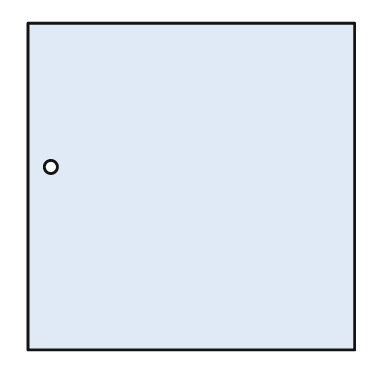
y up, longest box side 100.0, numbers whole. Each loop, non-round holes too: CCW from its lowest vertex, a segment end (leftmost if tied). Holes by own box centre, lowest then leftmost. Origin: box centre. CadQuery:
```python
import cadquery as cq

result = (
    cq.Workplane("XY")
    .moveTo(-50.0, -50.0)
    .lineTo(50.0, -50.0)
    .lineTo(50.0, 50.0)
    .lineTo(-50.0, 50.0)
    .close()
    .moveTo(-43.0, 6.0)
    .circle(2.0)
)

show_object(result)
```